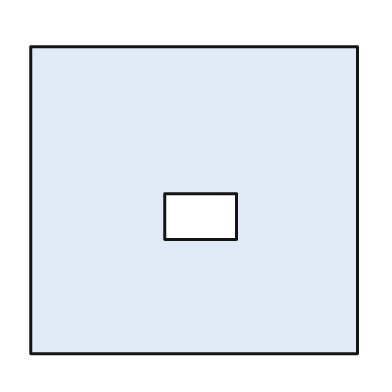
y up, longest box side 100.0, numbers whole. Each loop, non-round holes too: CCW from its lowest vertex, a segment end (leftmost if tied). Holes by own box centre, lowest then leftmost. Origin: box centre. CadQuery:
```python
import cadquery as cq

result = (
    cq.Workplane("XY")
    .moveTo(-50.0, -47.0)
    .lineTo(50.0, -47.0)
    .lineTo(50.0, 47.0)
    .lineTo(-50.0, 47.0)
    .close()
    .moveTo(-9.0, -12.0)
    .lineTo(13.0, -12.0)
    .lineTo(13.0, 2.0)
    .lineTo(-9.0, 2.0)
    .close()
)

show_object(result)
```